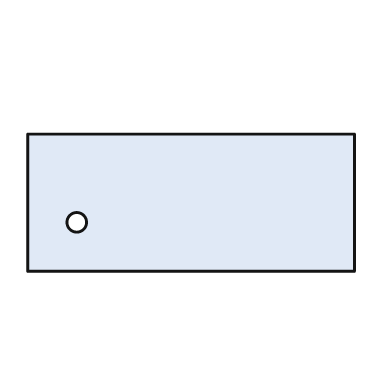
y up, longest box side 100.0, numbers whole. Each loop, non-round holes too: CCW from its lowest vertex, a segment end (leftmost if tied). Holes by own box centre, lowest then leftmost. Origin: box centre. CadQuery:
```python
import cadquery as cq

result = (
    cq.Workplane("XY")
    .moveTo(-50.0, -21.0)
    .lineTo(50.0, -21.0)
    .lineTo(50.0, 21.0)
    .lineTo(-50.0, 21.0)
    .close()
    .moveTo(-35.0, -6.0)
    .circle(3.0)
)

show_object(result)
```